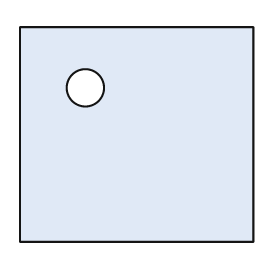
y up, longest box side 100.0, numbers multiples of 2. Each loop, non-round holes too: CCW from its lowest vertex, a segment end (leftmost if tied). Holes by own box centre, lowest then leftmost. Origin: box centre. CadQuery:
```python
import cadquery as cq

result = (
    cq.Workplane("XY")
    .moveTo(-50.0, -46.0)
    .lineTo(50.0, -46.0)
    .lineTo(50.0, 46.0)
    .lineTo(-50.0, 46.0)
    .close()
    .moveTo(-22.0, 20.0)
    .circle(8.0)
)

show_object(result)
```